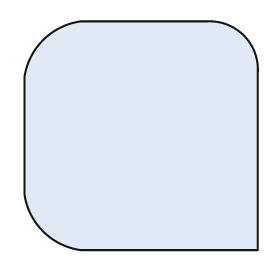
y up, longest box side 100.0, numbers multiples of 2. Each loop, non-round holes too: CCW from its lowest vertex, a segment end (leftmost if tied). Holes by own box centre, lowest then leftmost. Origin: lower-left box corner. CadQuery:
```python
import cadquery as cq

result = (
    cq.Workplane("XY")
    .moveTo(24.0, 0.0)
    .lineTo(100.0, 0.0)
    .lineTo(100.0, 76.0)
    .threePointArc((94.0, 92.0), (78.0, 98.0))
    .lineTo(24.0, 98.0)
    .threePointArc((8.0, 90.0), (0.0, 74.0))
    .lineTo(0.0, 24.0)
    .threePointArc((8.0, 8.0), (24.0, 0.0))
    .close()
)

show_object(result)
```